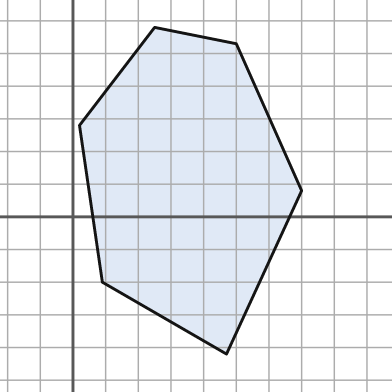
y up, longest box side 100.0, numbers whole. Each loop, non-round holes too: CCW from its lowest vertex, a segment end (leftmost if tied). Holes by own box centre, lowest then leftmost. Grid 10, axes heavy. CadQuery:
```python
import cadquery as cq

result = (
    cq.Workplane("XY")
    .moveTo(47.0, -42.0)
    .lineTo(70.0, 8.0)
    .lineTo(50.0, 53.0)
    .lineTo(25.0, 58.0)
    .lineTo(2.0, 28.0)
    .lineTo(9.0, -20.0)
    .close()
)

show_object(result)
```